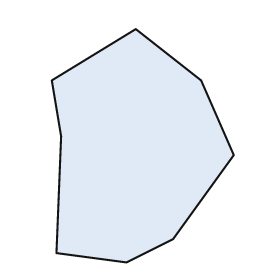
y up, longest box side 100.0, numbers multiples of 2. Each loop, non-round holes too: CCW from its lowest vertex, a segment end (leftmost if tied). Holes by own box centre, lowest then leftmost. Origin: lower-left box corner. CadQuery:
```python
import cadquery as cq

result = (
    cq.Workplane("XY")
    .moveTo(32.0, 0.0)
    .lineTo(52.0, 10.0)
    .lineTo(78.0, 46.0)
    .lineTo(64.0, 78.0)
    .lineTo(36.0, 100.0)
    .lineTo(0.0, 78.0)
    .lineTo(4.0, 54.0)
    .lineTo(2.0, 4.0)
    .close()
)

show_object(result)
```